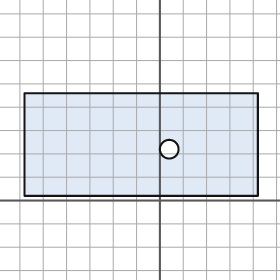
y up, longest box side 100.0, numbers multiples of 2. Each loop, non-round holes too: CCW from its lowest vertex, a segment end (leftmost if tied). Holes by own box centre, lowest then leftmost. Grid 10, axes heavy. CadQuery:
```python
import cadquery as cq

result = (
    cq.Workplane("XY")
    .moveTo(-58.0, 2.0)
    .lineTo(42.0, 2.0)
    .lineTo(42.0, 46.0)
    .lineTo(-58.0, 46.0)
    .close()
    .moveTo(4.0, 22.0)
    .circle(4.0)
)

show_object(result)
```